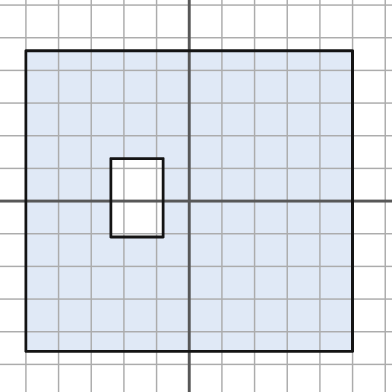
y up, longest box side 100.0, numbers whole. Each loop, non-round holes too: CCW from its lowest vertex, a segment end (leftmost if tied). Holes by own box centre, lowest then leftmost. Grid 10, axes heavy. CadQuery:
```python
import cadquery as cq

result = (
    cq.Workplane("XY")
    .moveTo(-50.0, -46.0)
    .lineTo(50.0, -46.0)
    .lineTo(50.0, 46.0)
    .lineTo(-50.0, 46.0)
    .close()
    .moveTo(-24.0, -11.0)
    .lineTo(-8.0, -11.0)
    .lineTo(-8.0, 13.0)
    .lineTo(-24.0, 13.0)
    .close()
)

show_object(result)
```